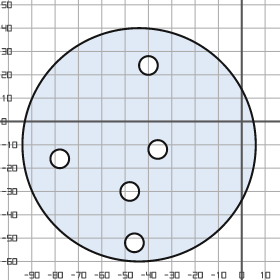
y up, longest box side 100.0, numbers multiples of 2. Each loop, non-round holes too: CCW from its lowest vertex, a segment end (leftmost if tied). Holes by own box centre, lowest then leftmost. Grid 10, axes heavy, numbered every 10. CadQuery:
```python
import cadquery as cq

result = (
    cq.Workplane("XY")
    .moveTo(-44.0, -10.0)
    .circle(50.0)
    .moveTo(-46.0, -52.0)
    .circle(4.0)
    .moveTo(-48.0, -30.0)
    .circle(4.0)
    .moveTo(-78.0, -16.0)
    .circle(4.0)
    .moveTo(-36.0, -12.0)
    .circle(4.0)
    .moveTo(-40.0, 24.0)
    .circle(4.0)
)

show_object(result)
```